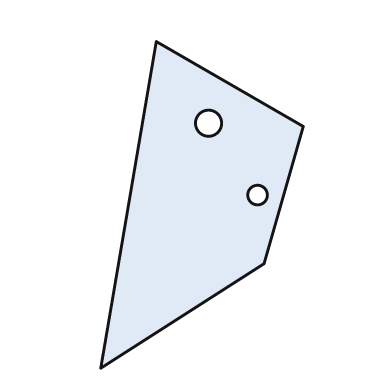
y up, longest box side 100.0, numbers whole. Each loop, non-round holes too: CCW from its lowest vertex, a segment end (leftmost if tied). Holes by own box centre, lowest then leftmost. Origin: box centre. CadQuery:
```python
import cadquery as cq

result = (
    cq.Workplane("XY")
    .moveTo(-31.0, -50.0)
    .lineTo(19.0, -18.0)
    .lineTo(31.0, 24.0)
    .lineTo(-14.0, 50.0)
    .close()
    .moveTo(17.0, 3.0)
    .circle(3.0)
    .moveTo(2.0, 25.0)
    .circle(4.0)
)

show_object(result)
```